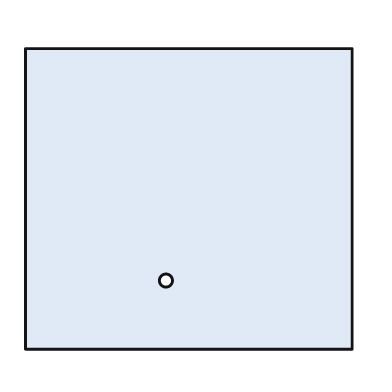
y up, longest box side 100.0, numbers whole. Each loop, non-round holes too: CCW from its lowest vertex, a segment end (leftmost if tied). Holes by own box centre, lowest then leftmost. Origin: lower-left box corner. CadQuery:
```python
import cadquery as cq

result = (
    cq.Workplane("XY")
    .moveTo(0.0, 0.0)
    .lineTo(100.0, 0.0)
    .lineTo(100.0, 92.0)
    .lineTo(0.0, 92.0)
    .close()
    .moveTo(43.0, 21.0)
    .circle(2.0)
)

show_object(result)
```